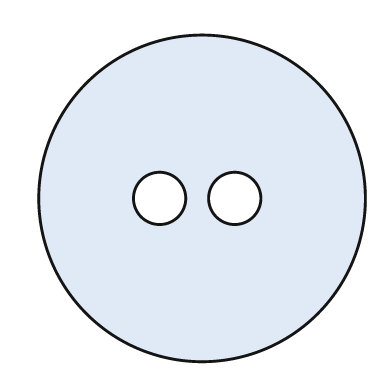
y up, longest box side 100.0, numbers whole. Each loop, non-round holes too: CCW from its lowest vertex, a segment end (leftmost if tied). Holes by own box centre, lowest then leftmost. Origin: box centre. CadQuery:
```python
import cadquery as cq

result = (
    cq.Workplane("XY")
    .moveTo(0.0, 0.0)
    .circle(50.0)
    .moveTo(-13.0, 0.0)
    .circle(8.0)
    .moveTo(10.0, 0.0)
    .circle(8.0)
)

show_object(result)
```